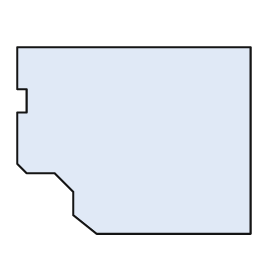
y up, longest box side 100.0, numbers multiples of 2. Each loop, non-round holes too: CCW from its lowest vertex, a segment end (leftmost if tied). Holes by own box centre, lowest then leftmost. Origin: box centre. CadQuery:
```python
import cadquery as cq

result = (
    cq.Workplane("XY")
    .moveTo(-16.0, -40.0)
    .lineTo(50.0, -40.0)
    .lineTo(50.0, 40.0)
    .lineTo(-50.0, 40.0)
    .lineTo(-50.0, 22.0)
    .lineTo(-46.0, 22.0)
    .lineTo(-46.0, 12.0)
    .lineTo(-50.0, 12.0)
    .lineTo(-50.0, -10.0)
    .lineTo(-46.0, -14.0)
    .lineTo(-34.0, -14.0)
    .lineTo(-26.0, -22.0)
    .lineTo(-26.0, -32.0)
    .close()
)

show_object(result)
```